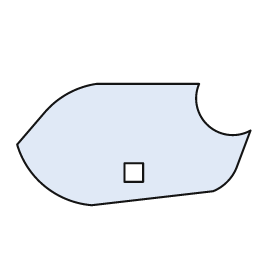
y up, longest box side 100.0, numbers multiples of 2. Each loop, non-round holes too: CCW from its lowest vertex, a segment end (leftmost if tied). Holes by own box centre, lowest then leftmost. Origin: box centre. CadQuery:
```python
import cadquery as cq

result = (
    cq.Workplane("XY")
    .moveTo(-18.0, -26.0)
    .lineTo(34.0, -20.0)
    .threePointArc((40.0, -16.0), (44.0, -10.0))
    .lineTo(50.0, 6.0)
    .threePointArc((32.0, 8.0), (28.0, 26.0))
    .lineTo(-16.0, 26.0)
    .threePointArc((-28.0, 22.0), (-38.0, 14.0))
    .lineTo(-50.0, 0.0)
    .threePointArc((-38.0, -18.0), (-18.0, -26.0))
    .close()
    .moveTo(-4.0, -16.0)
    .lineTo(4.0, -16.0)
    .lineTo(4.0, -8.0)
    .lineTo(-4.0, -8.0)
    .close()
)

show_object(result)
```